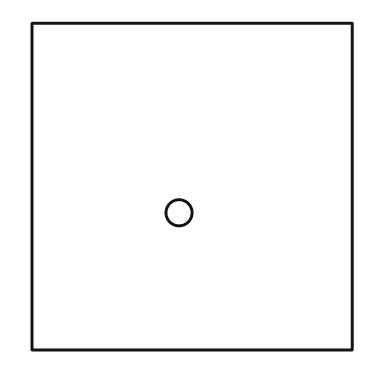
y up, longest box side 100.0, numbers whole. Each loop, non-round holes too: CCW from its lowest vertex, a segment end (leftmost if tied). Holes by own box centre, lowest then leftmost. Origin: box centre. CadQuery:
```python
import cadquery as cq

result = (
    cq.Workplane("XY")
    .moveTo(-49.0, -50.0)
    .lineTo(49.0, -50.0)
    .lineTo(49.0, 50.0)
    .lineTo(-49.0, 50.0)
    .close()
    .moveTo(-4.0, -8.0)
    .circle(4.0)
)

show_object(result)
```